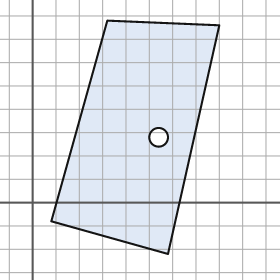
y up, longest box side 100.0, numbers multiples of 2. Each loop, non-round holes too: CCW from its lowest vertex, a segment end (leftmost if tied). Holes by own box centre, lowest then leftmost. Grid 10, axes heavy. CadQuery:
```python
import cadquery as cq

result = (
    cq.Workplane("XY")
    .moveTo(58.0, -22.0)
    .lineTo(80.0, 76.0)
    .lineTo(32.0, 78.0)
    .lineTo(8.0, -8.0)
    .close()
    .moveTo(54.0, 28.0)
    .circle(4.0)
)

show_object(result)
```